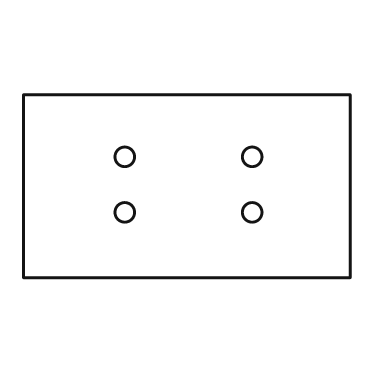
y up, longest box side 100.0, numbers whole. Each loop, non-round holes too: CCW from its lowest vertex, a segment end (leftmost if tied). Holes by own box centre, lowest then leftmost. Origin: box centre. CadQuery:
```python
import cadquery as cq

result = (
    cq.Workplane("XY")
    .moveTo(-50.0, -28.0)
    .lineTo(50.0, -28.0)
    .lineTo(50.0, 28.0)
    .lineTo(-50.0, 28.0)
    .close()
    .moveTo(-19.0, -8.0)
    .circle(3.0)
    .moveTo(20.0, -8.0)
    .circle(3.0)
    .moveTo(-19.0, 9.0)
    .circle(3.0)
    .moveTo(20.0, 9.0)
    .circle(3.0)
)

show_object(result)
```